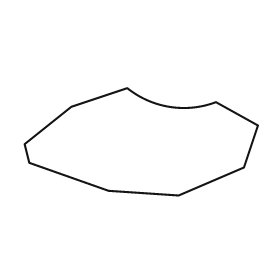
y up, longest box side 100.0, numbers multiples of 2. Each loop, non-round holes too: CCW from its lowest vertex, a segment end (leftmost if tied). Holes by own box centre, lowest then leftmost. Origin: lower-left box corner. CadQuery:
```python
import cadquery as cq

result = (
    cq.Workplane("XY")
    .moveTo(66.0, 0.0)
    .lineTo(94.0, 12.0)
    .lineTo(100.0, 30.0)
    .lineTo(82.0, 40.0)
    .threePointArc((62.0, 38.0), (44.0, 46.0))
    .lineTo(20.0, 38.0)
    .lineTo(0.0, 22.0)
    .lineTo(2.0, 14.0)
    .lineTo(36.0, 2.0)
    .close()
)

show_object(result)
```